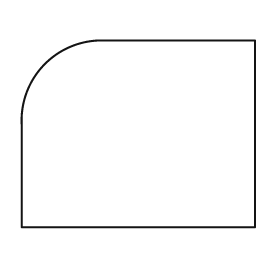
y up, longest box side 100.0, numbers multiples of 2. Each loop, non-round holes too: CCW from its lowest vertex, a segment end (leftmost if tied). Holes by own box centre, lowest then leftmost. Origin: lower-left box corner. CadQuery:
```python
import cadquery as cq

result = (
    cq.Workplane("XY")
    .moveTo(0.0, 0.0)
    .lineTo(100.0, 0.0)
    .lineTo(100.0, 80.0)
    .lineTo(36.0, 80.0)
    .threePointArc((10.0, 70.0), (0.0, 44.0))
    .close()
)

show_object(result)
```